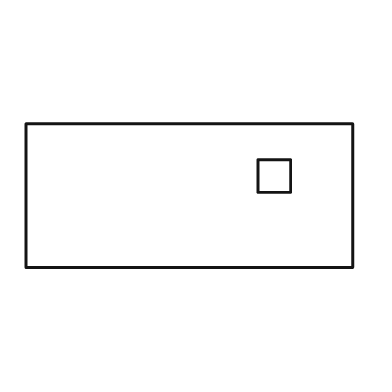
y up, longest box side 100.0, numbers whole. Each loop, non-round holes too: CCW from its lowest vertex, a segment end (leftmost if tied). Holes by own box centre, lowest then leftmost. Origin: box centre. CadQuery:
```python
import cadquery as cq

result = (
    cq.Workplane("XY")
    .moveTo(-50.0, -22.0)
    .lineTo(50.0, -22.0)
    .lineTo(50.0, 22.0)
    .lineTo(-50.0, 22.0)
    .close()
    .moveTo(21.0, 1.0)
    .lineTo(31.0, 1.0)
    .lineTo(31.0, 11.0)
    .lineTo(21.0, 11.0)
    .close()
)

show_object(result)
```